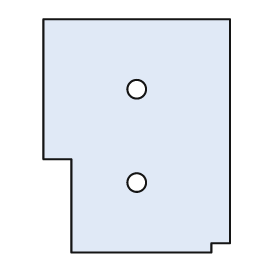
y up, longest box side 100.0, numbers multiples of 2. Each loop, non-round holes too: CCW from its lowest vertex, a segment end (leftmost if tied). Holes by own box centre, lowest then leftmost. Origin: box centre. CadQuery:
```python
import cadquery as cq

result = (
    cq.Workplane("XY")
    .moveTo(-28.0, -50.0)
    .lineTo(32.0, -50.0)
    .lineTo(32.0, -46.0)
    .lineTo(40.0, -46.0)
    .lineTo(40.0, 50.0)
    .lineTo(-40.0, 50.0)
    .lineTo(-40.0, -10.0)
    .lineTo(-28.0, -10.0)
    .close()
    .moveTo(0.0, -20.0)
    .circle(4.0)
    .moveTo(0.0, 20.0)
    .circle(4.0)
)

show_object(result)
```